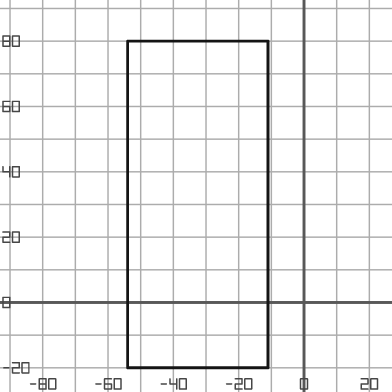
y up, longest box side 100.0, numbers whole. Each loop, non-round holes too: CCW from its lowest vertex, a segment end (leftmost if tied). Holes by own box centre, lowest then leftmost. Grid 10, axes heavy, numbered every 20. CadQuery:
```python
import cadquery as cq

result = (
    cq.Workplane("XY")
    .moveTo(-54.0, -20.0)
    .lineTo(-11.0, -20.0)
    .lineTo(-11.0, 80.0)
    .lineTo(-54.0, 80.0)
    .close()
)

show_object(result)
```